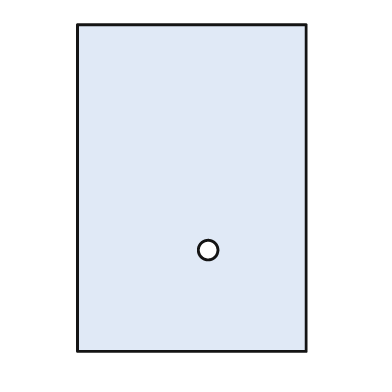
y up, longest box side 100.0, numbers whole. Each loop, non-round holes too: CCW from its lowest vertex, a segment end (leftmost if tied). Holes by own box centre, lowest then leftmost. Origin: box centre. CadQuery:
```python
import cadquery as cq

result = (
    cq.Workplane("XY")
    .moveTo(-35.0, -50.0)
    .lineTo(35.0, -50.0)
    .lineTo(35.0, 50.0)
    .lineTo(-35.0, 50.0)
    .close()
    .moveTo(5.0, -19.0)
    .circle(3.0)
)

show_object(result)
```